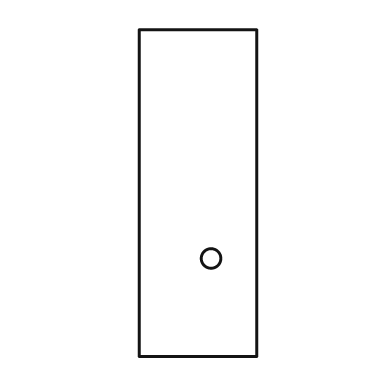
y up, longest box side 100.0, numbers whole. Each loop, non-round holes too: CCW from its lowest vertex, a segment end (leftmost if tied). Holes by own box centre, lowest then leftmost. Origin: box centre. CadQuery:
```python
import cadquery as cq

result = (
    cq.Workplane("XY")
    .moveTo(-18.0, -50.0)
    .lineTo(18.0, -50.0)
    .lineTo(18.0, 50.0)
    .lineTo(-18.0, 50.0)
    .close()
    .moveTo(4.0, -20.0)
    .circle(3.0)
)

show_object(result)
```